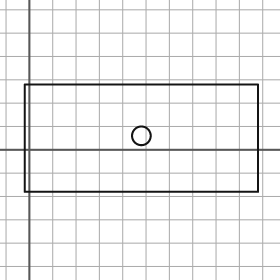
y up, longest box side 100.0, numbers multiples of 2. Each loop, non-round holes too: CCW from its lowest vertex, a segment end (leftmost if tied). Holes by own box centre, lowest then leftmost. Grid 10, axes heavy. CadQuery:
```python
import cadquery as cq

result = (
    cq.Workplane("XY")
    .moveTo(-2.0, -18.0)
    .lineTo(98.0, -18.0)
    .lineTo(98.0, 28.0)
    .lineTo(-2.0, 28.0)
    .close()
    .moveTo(48.0, 6.0)
    .circle(4.0)
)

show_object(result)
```